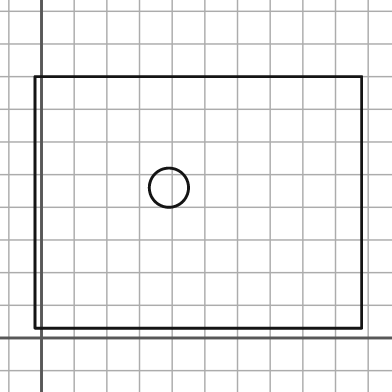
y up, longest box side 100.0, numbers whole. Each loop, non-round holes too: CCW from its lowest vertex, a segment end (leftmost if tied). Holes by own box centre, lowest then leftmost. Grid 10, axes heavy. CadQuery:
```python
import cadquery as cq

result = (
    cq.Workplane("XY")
    .moveTo(-2.0, 3.0)
    .lineTo(98.0, 3.0)
    .lineTo(98.0, 80.0)
    .lineTo(-2.0, 80.0)
    .close()
    .moveTo(39.0, 46.0)
    .circle(6.0)
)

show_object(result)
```